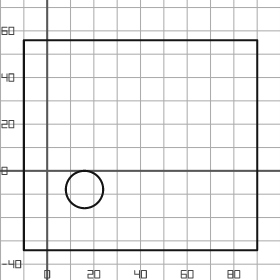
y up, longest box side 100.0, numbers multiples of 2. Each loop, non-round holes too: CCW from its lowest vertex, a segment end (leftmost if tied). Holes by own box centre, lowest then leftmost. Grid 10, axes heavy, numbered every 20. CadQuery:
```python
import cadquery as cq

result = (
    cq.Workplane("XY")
    .moveTo(-10.0, -34.0)
    .lineTo(90.0, -34.0)
    .lineTo(90.0, 56.0)
    .lineTo(-10.0, 56.0)
    .close()
    .moveTo(16.0, -8.0)
    .circle(8.0)
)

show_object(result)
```